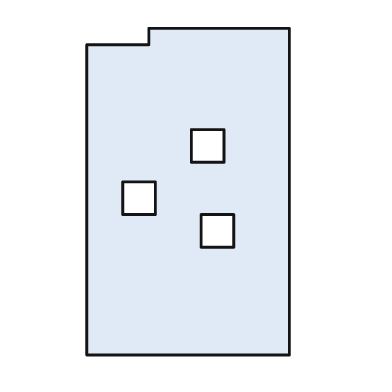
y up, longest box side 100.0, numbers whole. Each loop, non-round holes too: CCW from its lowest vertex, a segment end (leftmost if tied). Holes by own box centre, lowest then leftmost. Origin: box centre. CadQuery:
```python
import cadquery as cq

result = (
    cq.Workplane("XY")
    .moveTo(-31.0, -50.0)
    .lineTo(31.0, -50.0)
    .lineTo(31.0, 50.0)
    .lineTo(-12.0, 50.0)
    .lineTo(-12.0, 45.0)
    .lineTo(-31.0, 45.0)
    .close()
    .moveTo(4.0, -17.0)
    .lineTo(14.0, -17.0)
    .lineTo(14.0, -7.0)
    .lineTo(4.0, -7.0)
    .close()
    .moveTo(-20.0, -7.0)
    .lineTo(-10.0, -7.0)
    .lineTo(-10.0, 3.0)
    .lineTo(-20.0, 3.0)
    .close()
    .moveTo(1.0, 9.0)
    .lineTo(11.0, 9.0)
    .lineTo(11.0, 19.0)
    .lineTo(1.0, 19.0)
    .close()
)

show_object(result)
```